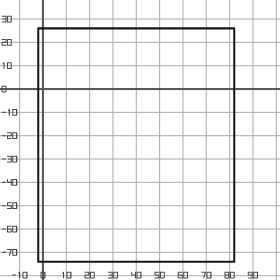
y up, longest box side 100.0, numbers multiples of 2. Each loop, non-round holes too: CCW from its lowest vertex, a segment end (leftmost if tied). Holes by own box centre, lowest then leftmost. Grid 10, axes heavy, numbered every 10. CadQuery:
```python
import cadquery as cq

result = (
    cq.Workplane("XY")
    .moveTo(-2.0, -74.0)
    .lineTo(82.0, -74.0)
    .lineTo(82.0, 26.0)
    .lineTo(-2.0, 26.0)
    .close()
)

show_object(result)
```